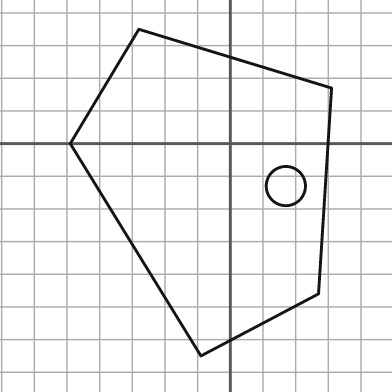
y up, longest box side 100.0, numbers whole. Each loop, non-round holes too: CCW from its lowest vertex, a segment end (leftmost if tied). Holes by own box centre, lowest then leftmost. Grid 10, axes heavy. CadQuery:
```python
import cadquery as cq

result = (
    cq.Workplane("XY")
    .moveTo(-9.0, -65.0)
    .lineTo(27.0, -46.0)
    .lineTo(31.0, 17.0)
    .lineTo(-28.0, 35.0)
    .lineTo(-49.0, 0.0)
    .close()
    .moveTo(17.0, -13.0)
    .circle(6.0)
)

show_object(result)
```